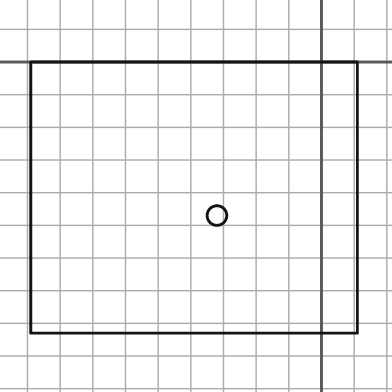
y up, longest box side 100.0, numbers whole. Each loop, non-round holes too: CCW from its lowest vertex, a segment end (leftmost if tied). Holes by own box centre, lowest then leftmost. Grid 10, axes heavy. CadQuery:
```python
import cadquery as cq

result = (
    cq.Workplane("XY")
    .moveTo(-89.0, -83.0)
    .lineTo(11.0, -83.0)
    .lineTo(11.0, 0.0)
    .lineTo(-89.0, 0.0)
    .close()
    .moveTo(-32.0, -47.0)
    .circle(3.0)
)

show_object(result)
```